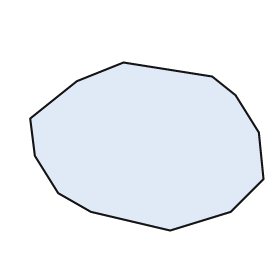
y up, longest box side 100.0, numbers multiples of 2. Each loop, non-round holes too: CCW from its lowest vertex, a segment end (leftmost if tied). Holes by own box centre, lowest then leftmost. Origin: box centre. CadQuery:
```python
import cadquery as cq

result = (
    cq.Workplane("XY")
    .moveTo(10.0, -36.0)
    .lineTo(36.0, -28.0)
    .lineTo(50.0, -14.0)
    .lineTo(48.0, 6.0)
    .lineTo(38.0, 22.0)
    .lineTo(28.0, 30.0)
    .lineTo(-10.0, 36.0)
    .lineTo(-30.0, 28.0)
    .lineTo(-50.0, 12.0)
    .lineTo(-48.0, -4.0)
    .lineTo(-38.0, -20.0)
    .lineTo(-24.0, -28.0)
    .close()
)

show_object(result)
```